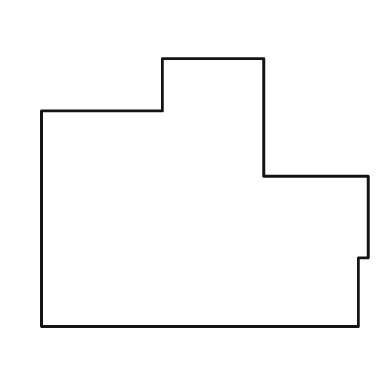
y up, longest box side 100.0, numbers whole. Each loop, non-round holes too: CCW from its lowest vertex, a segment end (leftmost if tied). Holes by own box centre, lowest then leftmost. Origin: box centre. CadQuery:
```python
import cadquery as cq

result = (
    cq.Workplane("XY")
    .moveTo(-50.0, -41.0)
    .lineTo(47.0, -41.0)
    .lineTo(47.0, -20.0)
    .lineTo(50.0, -20.0)
    .lineTo(50.0, 5.0)
    .lineTo(18.0, 5.0)
    .lineTo(18.0, 41.0)
    .lineTo(-13.0, 41.0)
    .lineTo(-13.0, 25.0)
    .lineTo(-50.0, 25.0)
    .close()
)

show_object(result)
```